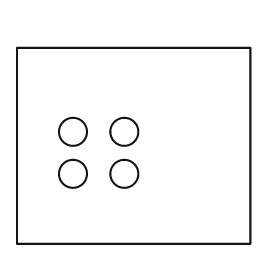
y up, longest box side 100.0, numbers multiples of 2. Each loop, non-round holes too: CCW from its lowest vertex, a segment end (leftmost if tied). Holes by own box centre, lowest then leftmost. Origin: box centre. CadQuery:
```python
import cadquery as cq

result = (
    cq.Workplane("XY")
    .moveTo(-50.0, -42.0)
    .lineTo(50.0, -42.0)
    .lineTo(50.0, 42.0)
    .lineTo(-50.0, 42.0)
    .close()
    .moveTo(-26.0, -12.0)
    .circle(6.0)
    .moveTo(-4.0, -12.0)
    .circle(6.0)
    .moveTo(-26.0, 6.0)
    .circle(6.0)
    .moveTo(-4.0, 6.0)
    .circle(6.0)
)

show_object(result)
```